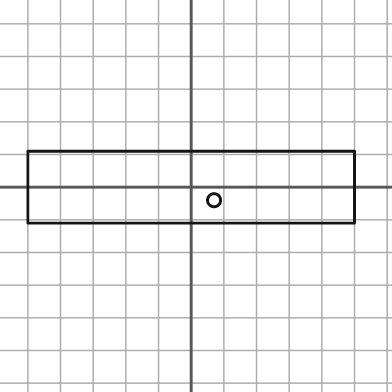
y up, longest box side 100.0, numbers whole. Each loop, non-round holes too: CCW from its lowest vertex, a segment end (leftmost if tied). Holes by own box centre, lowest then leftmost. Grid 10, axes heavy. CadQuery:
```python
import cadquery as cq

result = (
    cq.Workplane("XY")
    .moveTo(-50.0, -11.0)
    .lineTo(50.0, -11.0)
    .lineTo(50.0, 11.0)
    .lineTo(-50.0, 11.0)
    .close()
    .moveTo(7.0, -4.0)
    .circle(2.0)
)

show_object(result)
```